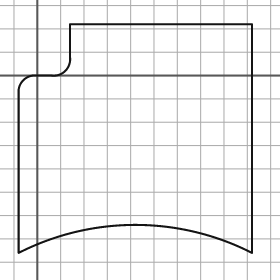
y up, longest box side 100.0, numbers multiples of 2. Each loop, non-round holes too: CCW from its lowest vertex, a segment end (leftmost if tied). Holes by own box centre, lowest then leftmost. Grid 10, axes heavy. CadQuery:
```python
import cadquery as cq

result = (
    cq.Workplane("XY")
    .moveTo(-8.0, -76.0)
    .threePointArc((42.0, -64.0), (92.0, -76.0))
    .lineTo(92.0, 22.0)
    .lineTo(14.0, 22.0)
    .lineTo(14.0, 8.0)
    .threePointArc((12.0, 2.0), (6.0, 0.0))
    .lineTo(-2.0, 0.0)
    .threePointArc((-6.0, -2.0), (-8.0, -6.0))
    .close()
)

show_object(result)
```